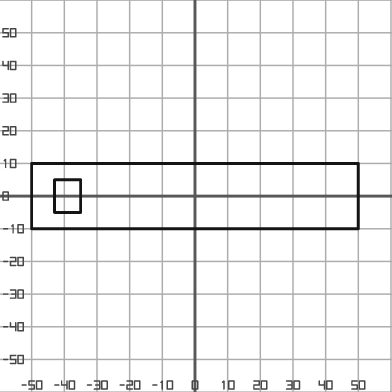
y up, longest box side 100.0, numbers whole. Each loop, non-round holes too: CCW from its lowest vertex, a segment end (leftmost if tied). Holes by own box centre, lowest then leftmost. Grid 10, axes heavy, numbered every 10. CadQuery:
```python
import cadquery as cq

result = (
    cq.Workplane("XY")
    .moveTo(-50.0, -10.0)
    .lineTo(50.0, -10.0)
    .lineTo(50.0, 10.0)
    .lineTo(-50.0, 10.0)
    .close()
    .moveTo(-43.0, -5.0)
    .lineTo(-35.0, -5.0)
    .lineTo(-35.0, 5.0)
    .lineTo(-43.0, 5.0)
    .close()
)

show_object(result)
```